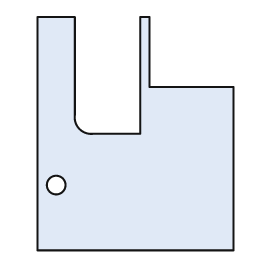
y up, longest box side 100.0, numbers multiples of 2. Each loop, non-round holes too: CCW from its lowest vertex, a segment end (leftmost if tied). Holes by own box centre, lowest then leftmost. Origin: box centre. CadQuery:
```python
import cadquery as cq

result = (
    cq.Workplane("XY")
    .moveTo(-42.0, -50.0)
    .lineTo(42.0, -50.0)
    .lineTo(42.0, 20.0)
    .lineTo(6.0, 20.0)
    .lineTo(6.0, 50.0)
    .lineTo(2.0, 50.0)
    .lineTo(2.0, 0.0)
    .lineTo(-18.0, 0.0)
    .threePointArc((-24.0, 2.0), (-26.0, 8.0))
    .lineTo(-26.0, 50.0)
    .lineTo(-42.0, 50.0)
    .close()
    .moveTo(-34.0, -22.0)
    .circle(4.0)
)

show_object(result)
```